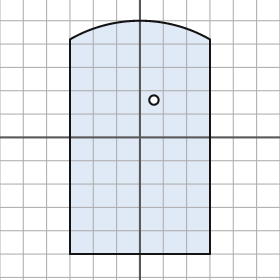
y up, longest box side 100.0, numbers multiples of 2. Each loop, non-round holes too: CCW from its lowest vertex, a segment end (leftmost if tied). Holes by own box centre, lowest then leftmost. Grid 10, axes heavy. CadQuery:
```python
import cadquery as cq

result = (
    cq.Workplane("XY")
    .moveTo(-30.0, -50.0)
    .lineTo(30.0, -50.0)
    .lineTo(30.0, 42.0)
    .threePointArc((0.0, 50.0), (-30.0, 42.0))
    .close()
    .moveTo(6.0, 16.0)
    .circle(2.0)
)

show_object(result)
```